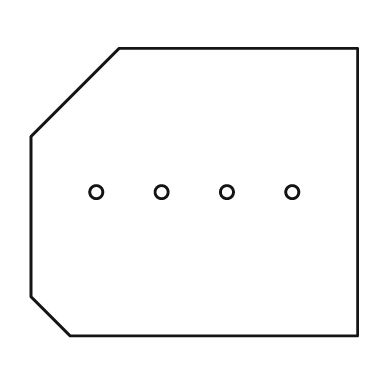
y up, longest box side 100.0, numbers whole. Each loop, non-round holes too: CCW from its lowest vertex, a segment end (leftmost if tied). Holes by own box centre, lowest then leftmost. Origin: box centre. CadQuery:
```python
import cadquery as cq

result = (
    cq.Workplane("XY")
    .moveTo(-38.0, -44.0)
    .lineTo(50.0, -44.0)
    .lineTo(50.0, 44.0)
    .lineTo(-23.0, 44.0)
    .lineTo(-50.0, 17.0)
    .lineTo(-50.0, -32.0)
    .close()
    .moveTo(-30.0, 0.0)
    .circle(2.0)
    .moveTo(-10.0, 0.0)
    .circle(2.0)
    .moveTo(10.0, 0.0)
    .circle(2.0)
    .moveTo(30.0, 0.0)
    .circle(2.0)
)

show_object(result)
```